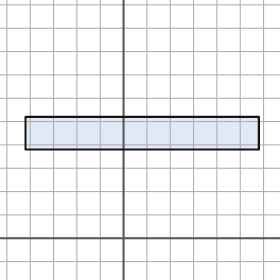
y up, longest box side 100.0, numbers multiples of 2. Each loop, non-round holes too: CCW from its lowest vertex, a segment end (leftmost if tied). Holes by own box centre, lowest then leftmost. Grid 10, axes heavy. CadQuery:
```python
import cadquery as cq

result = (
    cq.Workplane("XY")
    .moveTo(-42.0, 38.0)
    .lineTo(58.0, 38.0)
    .lineTo(58.0, 52.0)
    .lineTo(-42.0, 52.0)
    .close()
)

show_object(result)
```